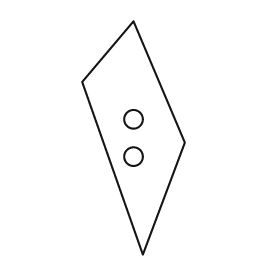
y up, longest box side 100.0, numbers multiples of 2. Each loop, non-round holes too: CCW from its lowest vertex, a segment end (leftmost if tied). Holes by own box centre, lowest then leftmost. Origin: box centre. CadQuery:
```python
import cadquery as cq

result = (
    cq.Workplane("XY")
    .moveTo(4.0, -50.0)
    .lineTo(22.0, -2.0)
    .lineTo(0.0, 50.0)
    .lineTo(-22.0, 24.0)
    .close()
    .moveTo(0.0, -8.0)
    .circle(4.0)
    .moveTo(0.0, 8.0)
    .circle(4.0)
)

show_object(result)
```